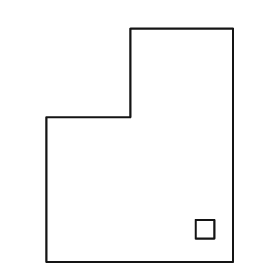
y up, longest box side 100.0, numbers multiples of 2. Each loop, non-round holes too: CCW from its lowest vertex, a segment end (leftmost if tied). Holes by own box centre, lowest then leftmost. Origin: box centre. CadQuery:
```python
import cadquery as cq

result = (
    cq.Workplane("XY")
    .moveTo(-40.0, -50.0)
    .lineTo(40.0, -50.0)
    .lineTo(40.0, 50.0)
    .lineTo(-4.0, 50.0)
    .lineTo(-4.0, 12.0)
    .lineTo(-40.0, 12.0)
    .close()
    .moveTo(24.0, -40.0)
    .lineTo(32.0, -40.0)
    .lineTo(32.0, -32.0)
    .lineTo(24.0, -32.0)
    .close()
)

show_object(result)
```